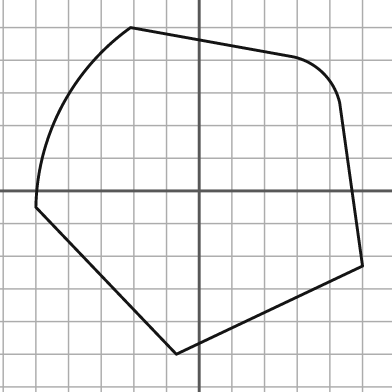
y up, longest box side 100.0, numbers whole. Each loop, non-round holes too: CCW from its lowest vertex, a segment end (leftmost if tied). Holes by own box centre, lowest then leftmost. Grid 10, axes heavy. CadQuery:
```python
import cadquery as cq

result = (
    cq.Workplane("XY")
    .moveTo(-7.0, -50.0)
    .lineTo(50.0, -23.0)
    .lineTo(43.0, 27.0)
    .threePointArc((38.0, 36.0), (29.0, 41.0))
    .lineTo(-21.0, 50.0)
    .threePointArc((-42.0, 26.0), (-50.0, -5.0))
    .close()
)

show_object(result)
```